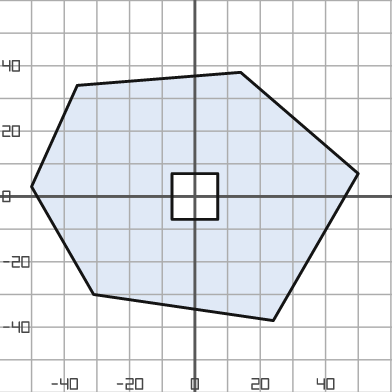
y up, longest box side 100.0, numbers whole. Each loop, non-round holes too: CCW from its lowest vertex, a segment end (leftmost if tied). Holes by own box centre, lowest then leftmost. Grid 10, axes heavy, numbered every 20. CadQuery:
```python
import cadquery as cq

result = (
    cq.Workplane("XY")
    .moveTo(24.0, -38.0)
    .lineTo(50.0, 7.0)
    .lineTo(14.0, 38.0)
    .lineTo(-36.0, 34.0)
    .lineTo(-50.0, 3.0)
    .lineTo(-31.0, -30.0)
    .close()
    .moveTo(-7.0, -7.0)
    .lineTo(7.0, -7.0)
    .lineTo(7.0, 7.0)
    .lineTo(-7.0, 7.0)
    .close()
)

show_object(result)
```